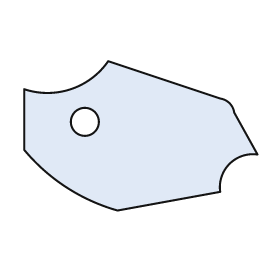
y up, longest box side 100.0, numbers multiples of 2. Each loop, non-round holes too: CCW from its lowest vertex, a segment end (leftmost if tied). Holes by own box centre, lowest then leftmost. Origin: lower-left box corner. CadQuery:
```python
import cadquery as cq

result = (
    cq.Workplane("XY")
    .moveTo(40.0, 0.0)
    .lineTo(84.0, 8.0)
    .threePointArc((88.0, 20.0), (100.0, 24.0))
    .lineTo(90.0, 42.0)
    .threePointArc((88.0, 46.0), (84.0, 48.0))
    .lineTo(36.0, 64.0)
    .threePointArc((20.0, 52.0), (0.0, 52.0))
    .lineTo(0.0, 26.0)
    .threePointArc((18.0, 10.0), (40.0, 0.0))
    .close()
    .moveTo(26.0, 38.0)
    .circle(6.0)
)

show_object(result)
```